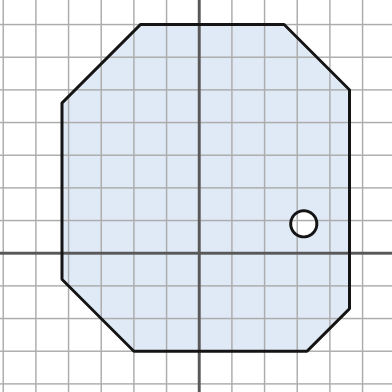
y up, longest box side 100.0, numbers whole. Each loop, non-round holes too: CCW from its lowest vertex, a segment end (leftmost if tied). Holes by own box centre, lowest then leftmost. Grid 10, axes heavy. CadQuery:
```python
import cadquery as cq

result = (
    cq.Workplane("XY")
    .moveTo(-20.0, -30.0)
    .lineTo(33.0, -30.0)
    .lineTo(46.0, -17.0)
    .lineTo(46.0, 50.0)
    .lineTo(26.0, 70.0)
    .lineTo(-18.0, 70.0)
    .lineTo(-42.0, 46.0)
    .lineTo(-42.0, -8.0)
    .close()
    .moveTo(32.0, 9.0)
    .circle(4.0)
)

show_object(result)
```